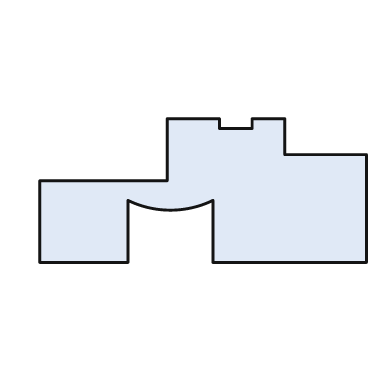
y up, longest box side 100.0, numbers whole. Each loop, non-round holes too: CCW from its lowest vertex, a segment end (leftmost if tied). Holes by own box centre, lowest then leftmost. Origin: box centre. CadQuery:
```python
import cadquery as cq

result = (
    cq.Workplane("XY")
    .moveTo(-50.0, -22.0)
    .lineTo(-23.0, -22.0)
    .lineTo(-23.0, -3.0)
    .threePointArc((-10.0, -6.0), (3.0, -3.0))
    .lineTo(3.0, -22.0)
    .lineTo(50.0, -22.0)
    .lineTo(50.0, 11.0)
    .lineTo(25.0, 11.0)
    .lineTo(25.0, 22.0)
    .lineTo(15.0, 22.0)
    .lineTo(15.0, 19.0)
    .lineTo(5.0, 19.0)
    .lineTo(5.0, 22.0)
    .lineTo(-11.0, 22.0)
    .lineTo(-11.0, 3.0)
    .lineTo(-50.0, 3.0)
    .close()
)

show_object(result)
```